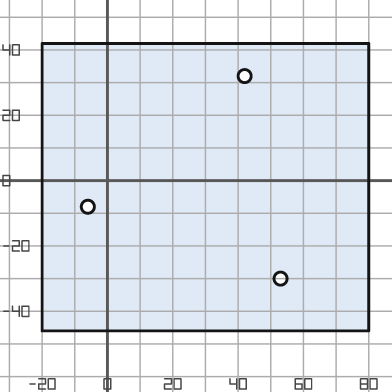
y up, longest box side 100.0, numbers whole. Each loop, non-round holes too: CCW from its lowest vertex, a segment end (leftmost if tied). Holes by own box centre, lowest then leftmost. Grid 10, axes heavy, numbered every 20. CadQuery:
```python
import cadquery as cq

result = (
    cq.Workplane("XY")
    .moveTo(-20.0, -46.0)
    .lineTo(80.0, -46.0)
    .lineTo(80.0, 42.0)
    .lineTo(-20.0, 42.0)
    .close()
    .moveTo(53.0, -30.0)
    .circle(2.0)
    .moveTo(-6.0, -8.0)
    .circle(2.0)
    .moveTo(42.0, 32.0)
    .circle(2.0)
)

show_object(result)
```